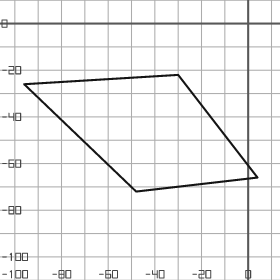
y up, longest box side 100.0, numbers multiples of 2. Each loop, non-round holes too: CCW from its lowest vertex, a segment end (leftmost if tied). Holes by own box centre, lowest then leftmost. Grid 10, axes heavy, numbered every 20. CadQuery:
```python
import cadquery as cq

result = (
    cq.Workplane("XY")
    .moveTo(-48.0, -72.0)
    .lineTo(4.0, -66.0)
    .lineTo(-30.0, -22.0)
    .lineTo(-96.0, -26.0)
    .close()
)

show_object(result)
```